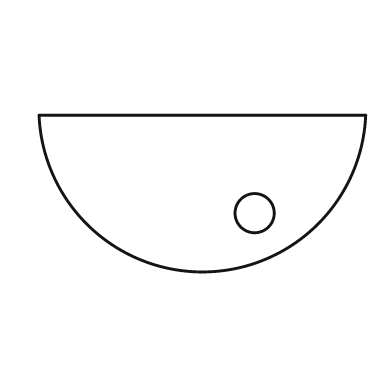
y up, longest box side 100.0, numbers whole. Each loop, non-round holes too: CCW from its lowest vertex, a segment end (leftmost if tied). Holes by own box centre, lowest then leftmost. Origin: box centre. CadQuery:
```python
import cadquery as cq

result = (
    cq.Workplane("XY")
    .moveTo(-50.0, 24.0)
    .threePointArc((0.0, -24.0), (50.0, 24.0))
    .close()
    .moveTo(16.0, -6.0)
    .circle(6.0)
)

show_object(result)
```